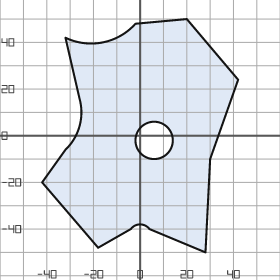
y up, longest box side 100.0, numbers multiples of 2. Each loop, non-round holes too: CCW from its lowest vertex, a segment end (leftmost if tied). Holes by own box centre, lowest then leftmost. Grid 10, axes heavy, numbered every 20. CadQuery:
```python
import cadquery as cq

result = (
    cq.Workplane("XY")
    .moveTo(28.0, -50.0)
    .lineTo(30.0, -10.0)
    .lineTo(42.0, 24.0)
    .lineTo(20.0, 50.0)
    .lineTo(-2.0, 48.0)
    .threePointArc((-16.0, 40.0), (-32.0, 42.0))
    .lineTo(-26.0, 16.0)
    .threePointArc((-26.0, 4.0), (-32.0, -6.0))
    .lineTo(-42.0, -20.0)
    .lineTo(-18.0, -48.0)
    .lineTo(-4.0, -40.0)
    .threePointArc((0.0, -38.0), (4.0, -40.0))
    .close()
    .moveTo(6.0, -2.0)
    .circle(8.0)
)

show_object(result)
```